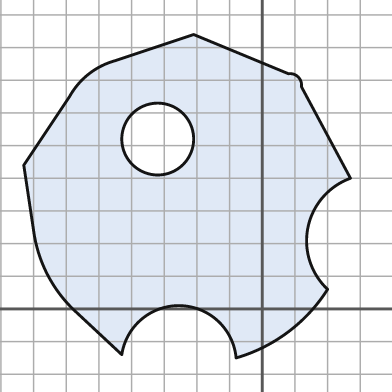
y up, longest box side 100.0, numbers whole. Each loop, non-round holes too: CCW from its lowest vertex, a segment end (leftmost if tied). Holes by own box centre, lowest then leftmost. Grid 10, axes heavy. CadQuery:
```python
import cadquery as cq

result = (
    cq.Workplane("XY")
    .moveTo(-8.0, -15.0)
    .threePointArc((8.0, -7.0), (20.0, 6.0))
    .threePointArc((14.0, 25.0), (27.0, 40.0))
    .lineTo(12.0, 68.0)
    .threePointArc((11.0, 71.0), (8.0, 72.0))
    .lineTo(-21.0, 84.0)
    .lineTo(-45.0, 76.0)
    .threePointArc((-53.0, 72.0), (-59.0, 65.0))
    .lineTo(-73.0, 44.0)
    .lineTo(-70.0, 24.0)
    .threePointArc((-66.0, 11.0), (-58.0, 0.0))
    .lineTo(-43.0, -14.0)
    .threePointArc((-25.0, 1.0), (-8.0, -15.0))
    .close()
    .moveTo(-32.0, 52.0)
    .circle(11.0)
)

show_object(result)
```